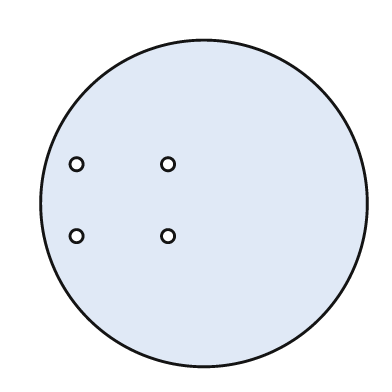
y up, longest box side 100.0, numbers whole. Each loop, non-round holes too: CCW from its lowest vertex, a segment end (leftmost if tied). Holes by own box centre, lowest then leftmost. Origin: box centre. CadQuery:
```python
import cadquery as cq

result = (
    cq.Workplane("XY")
    .moveTo(0.0, 0.0)
    .circle(50.0)
    .moveTo(-39.0, -10.0)
    .circle(2.0)
    .moveTo(-11.0, -10.0)
    .circle(2.0)
    .moveTo(-39.0, 12.0)
    .circle(2.0)
    .moveTo(-11.0, 12.0)
    .circle(2.0)
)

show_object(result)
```